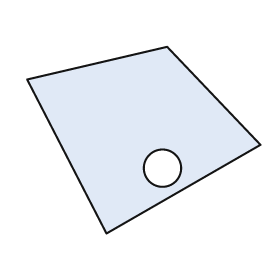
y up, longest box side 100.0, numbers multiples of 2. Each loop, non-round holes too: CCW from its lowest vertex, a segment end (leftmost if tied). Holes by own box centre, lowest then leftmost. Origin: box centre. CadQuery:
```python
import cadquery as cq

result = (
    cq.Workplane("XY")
    .moveTo(-16.0, -40.0)
    .lineTo(50.0, -2.0)
    .lineTo(10.0, 40.0)
    .lineTo(-50.0, 26.0)
    .close()
    .moveTo(8.0, -12.0)
    .circle(8.0)
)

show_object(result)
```